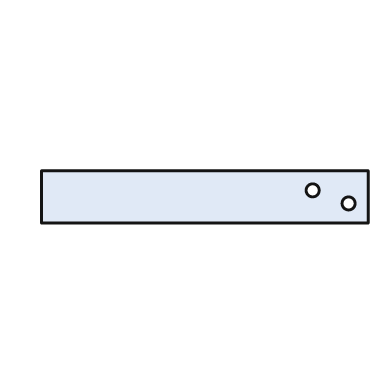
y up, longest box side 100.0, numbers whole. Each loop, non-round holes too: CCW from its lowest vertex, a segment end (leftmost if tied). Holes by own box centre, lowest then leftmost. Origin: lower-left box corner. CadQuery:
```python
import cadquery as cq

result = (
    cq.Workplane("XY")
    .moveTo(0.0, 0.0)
    .lineTo(100.0, 0.0)
    .lineTo(100.0, 16.0)
    .lineTo(0.0, 16.0)
    .close()
    .moveTo(94.0, 6.0)
    .circle(2.0)
    .moveTo(83.0, 10.0)
    .circle(2.0)
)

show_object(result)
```